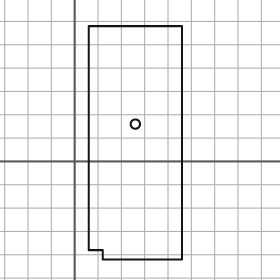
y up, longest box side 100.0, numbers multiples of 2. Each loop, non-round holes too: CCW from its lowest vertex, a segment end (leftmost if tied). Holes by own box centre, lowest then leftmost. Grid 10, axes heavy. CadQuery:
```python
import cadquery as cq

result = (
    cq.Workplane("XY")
    .moveTo(12.0, -42.0)
    .lineTo(46.0, -42.0)
    .lineTo(46.0, 58.0)
    .lineTo(6.0, 58.0)
    .lineTo(6.0, -38.0)
    .lineTo(12.0, -38.0)
    .close()
    .moveTo(26.0, 16.0)
    .circle(2.0)
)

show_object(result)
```